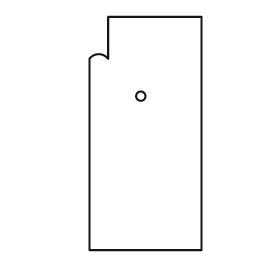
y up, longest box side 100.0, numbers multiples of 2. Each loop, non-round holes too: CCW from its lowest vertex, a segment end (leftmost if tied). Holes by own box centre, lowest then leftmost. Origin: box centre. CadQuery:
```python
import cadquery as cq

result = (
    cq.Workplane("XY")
    .moveTo(-24.0, -50.0)
    .lineTo(24.0, -50.0)
    .lineTo(24.0, 50.0)
    .lineTo(-16.0, 50.0)
    .lineTo(-16.0, 32.0)
    .threePointArc((-20.0, 34.0), (-24.0, 32.0))
    .close()
    .moveTo(-2.0, 16.0)
    .circle(2.0)
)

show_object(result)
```